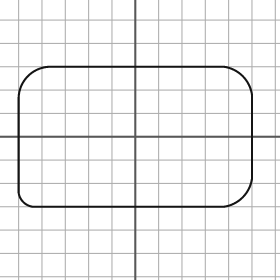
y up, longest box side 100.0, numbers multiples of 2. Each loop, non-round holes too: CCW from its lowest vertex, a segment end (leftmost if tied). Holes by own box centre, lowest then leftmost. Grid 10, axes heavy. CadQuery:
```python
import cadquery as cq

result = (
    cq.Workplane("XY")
    .moveTo(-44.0, -30.0)
    .lineTo(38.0, -30.0)
    .threePointArc((46.0, -26.0), (50.0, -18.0))
    .lineTo(50.0, 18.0)
    .threePointArc((46.0, 26.0), (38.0, 30.0))
    .lineTo(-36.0, 30.0)
    .threePointArc((-46.0, 26.0), (-50.0, 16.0))
    .lineTo(-50.0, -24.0)
    .threePointArc((-48.0, -28.0), (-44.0, -30.0))
    .close()
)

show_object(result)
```